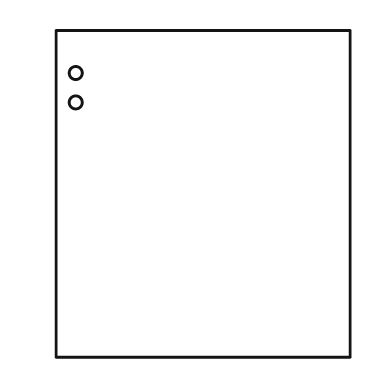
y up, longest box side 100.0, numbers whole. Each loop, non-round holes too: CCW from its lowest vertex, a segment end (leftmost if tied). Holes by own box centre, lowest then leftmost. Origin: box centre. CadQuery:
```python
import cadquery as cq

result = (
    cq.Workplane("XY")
    .moveTo(-45.0, -50.0)
    .lineTo(45.0, -50.0)
    .lineTo(45.0, 50.0)
    .lineTo(-45.0, 50.0)
    .close()
    .moveTo(-39.0, 28.0)
    .circle(2.0)
    .moveTo(-39.0, 37.0)
    .circle(2.0)
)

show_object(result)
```